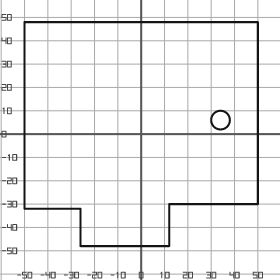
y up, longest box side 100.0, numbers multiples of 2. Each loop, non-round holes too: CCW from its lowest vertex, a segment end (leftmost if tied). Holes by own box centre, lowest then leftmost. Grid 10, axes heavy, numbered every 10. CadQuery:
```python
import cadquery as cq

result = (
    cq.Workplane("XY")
    .moveTo(-26.0, -48.0)
    .lineTo(12.0, -48.0)
    .lineTo(12.0, -30.0)
    .lineTo(50.0, -30.0)
    .lineTo(50.0, 48.0)
    .lineTo(-50.0, 48.0)
    .lineTo(-50.0, -32.0)
    .lineTo(-26.0, -32.0)
    .close()
    .moveTo(34.0, 6.0)
    .circle(4.0)
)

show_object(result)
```